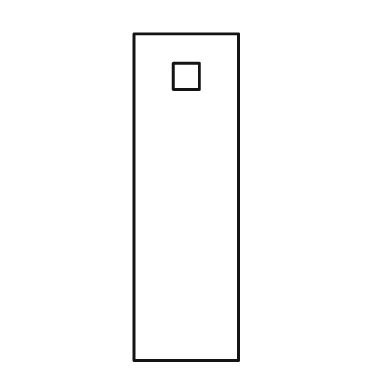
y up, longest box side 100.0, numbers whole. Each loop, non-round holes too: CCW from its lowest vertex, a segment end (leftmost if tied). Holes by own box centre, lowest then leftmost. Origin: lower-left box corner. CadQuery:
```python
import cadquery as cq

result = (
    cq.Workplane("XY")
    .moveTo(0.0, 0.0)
    .lineTo(32.0, 0.0)
    .lineTo(32.0, 100.0)
    .lineTo(0.0, 100.0)
    .close()
    .moveTo(12.0, 83.0)
    .lineTo(20.0, 83.0)
    .lineTo(20.0, 91.0)
    .lineTo(12.0, 91.0)
    .close()
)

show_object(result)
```